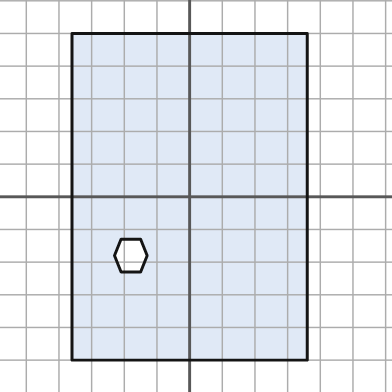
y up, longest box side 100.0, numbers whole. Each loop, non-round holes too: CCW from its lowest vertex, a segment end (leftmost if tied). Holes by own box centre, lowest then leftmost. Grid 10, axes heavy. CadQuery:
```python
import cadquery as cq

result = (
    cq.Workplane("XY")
    .moveTo(-36.0, -50.0)
    .lineTo(36.0, -50.0)
    .lineTo(36.0, 50.0)
    .lineTo(-36.0, 50.0)
    .close()
    .moveTo(-21.0, -23.0)
    .lineTo(-15.0, -23.0)
    .lineTo(-13.0, -18.0)
    .lineTo(-15.0, -13.0)
    .lineTo(-21.0, -13.0)
    .lineTo(-23.0, -18.0)
    .close()
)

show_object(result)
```